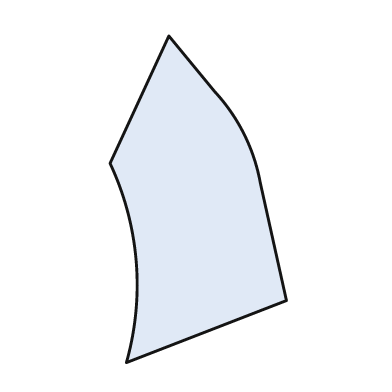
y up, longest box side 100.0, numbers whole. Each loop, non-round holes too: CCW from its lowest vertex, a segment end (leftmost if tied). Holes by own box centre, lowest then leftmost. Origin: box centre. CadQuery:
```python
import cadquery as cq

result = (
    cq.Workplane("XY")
    .moveTo(-22.0, -50.0)
    .lineTo(27.0, -31.0)
    .lineTo(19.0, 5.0)
    .threePointArc((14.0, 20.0), (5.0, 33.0))
    .lineTo(-9.0, 50.0)
    .lineTo(-27.0, 11.0)
    .threePointArc((-19.0, -19.0), (-22.0, -50.0))
    .close()
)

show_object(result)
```